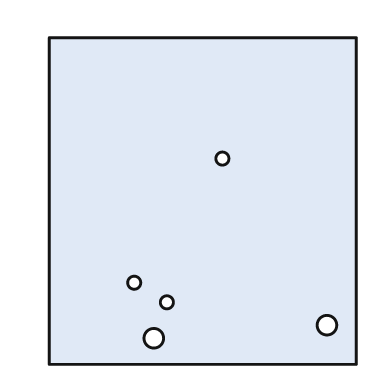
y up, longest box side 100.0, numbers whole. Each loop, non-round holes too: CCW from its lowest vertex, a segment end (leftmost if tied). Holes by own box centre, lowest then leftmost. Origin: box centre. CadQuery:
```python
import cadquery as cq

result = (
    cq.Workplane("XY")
    .moveTo(-47.0, -50.0)
    .lineTo(47.0, -50.0)
    .lineTo(47.0, 50.0)
    .lineTo(-47.0, 50.0)
    .close()
    .moveTo(-15.0, -42.0)
    .circle(3.0)
    .moveTo(38.0, -38.0)
    .circle(3.0)
    .moveTo(-11.0, -31.0)
    .circle(2.0)
    .moveTo(-21.0, -25.0)
    .circle(2.0)
    .moveTo(6.0, 13.0)
    .circle(2.0)
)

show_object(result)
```